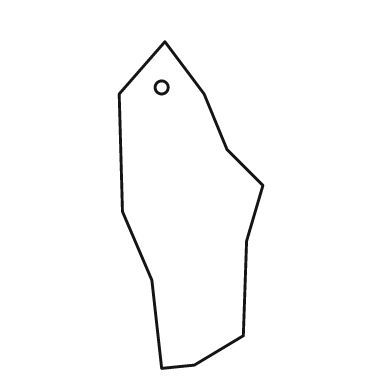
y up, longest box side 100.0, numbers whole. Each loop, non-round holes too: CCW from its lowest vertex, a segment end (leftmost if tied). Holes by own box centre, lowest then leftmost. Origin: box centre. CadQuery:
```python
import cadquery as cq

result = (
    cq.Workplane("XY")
    .moveTo(-9.0, -50.0)
    .lineTo(1.0, -49.0)
    .lineTo(16.0, -40.0)
    .lineTo(17.0, -11.0)
    .lineTo(22.0, 6.0)
    .lineTo(11.0, 17.0)
    .lineTo(4.0, 34.0)
    .lineTo(-8.0, 50.0)
    .lineTo(-22.0, 34.0)
    .lineTo(-21.0, -2.0)
    .lineTo(-12.0, -23.0)
    .close()
    .moveTo(-9.0, 36.0)
    .circle(2.0)
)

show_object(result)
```